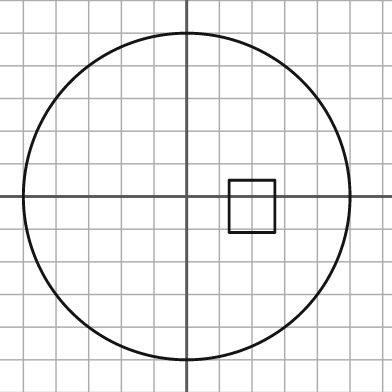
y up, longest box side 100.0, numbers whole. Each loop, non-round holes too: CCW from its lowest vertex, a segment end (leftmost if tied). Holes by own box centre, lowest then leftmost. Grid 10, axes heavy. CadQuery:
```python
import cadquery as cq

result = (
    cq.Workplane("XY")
    .moveTo(0.0, 0.0)
    .circle(50.0)
    .moveTo(13.0, -11.0)
    .lineTo(27.0, -11.0)
    .lineTo(27.0, 5.0)
    .lineTo(13.0, 5.0)
    .close()
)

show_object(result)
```